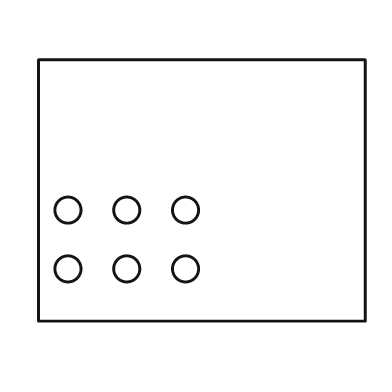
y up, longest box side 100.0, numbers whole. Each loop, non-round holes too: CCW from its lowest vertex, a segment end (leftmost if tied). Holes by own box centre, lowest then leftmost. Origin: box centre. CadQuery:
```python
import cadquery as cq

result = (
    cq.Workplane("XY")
    .moveTo(-50.0, -40.0)
    .lineTo(50.0, -40.0)
    .lineTo(50.0, 40.0)
    .lineTo(-50.0, 40.0)
    .close()
    .moveTo(-41.0, -24.0)
    .circle(4.0)
    .moveTo(-23.0, -24.0)
    .circle(4.0)
    .moveTo(-5.0, -24.0)
    .circle(4.0)
    .moveTo(-41.0, -6.0)
    .circle(4.0)
    .moveTo(-23.0, -6.0)
    .circle(4.0)
    .moveTo(-5.0, -6.0)
    .circle(4.0)
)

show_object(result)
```